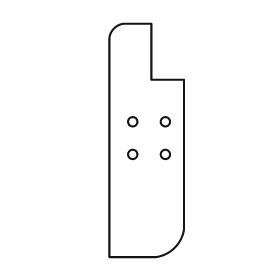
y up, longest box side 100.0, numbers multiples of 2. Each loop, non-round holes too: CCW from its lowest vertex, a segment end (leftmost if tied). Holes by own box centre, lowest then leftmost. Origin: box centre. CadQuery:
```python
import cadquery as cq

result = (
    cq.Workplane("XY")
    .moveTo(-16.0, -50.0)
    .lineTo(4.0, -50.0)
    .threePointArc((12.0, -46.0), (16.0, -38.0))
    .lineTo(16.0, 26.0)
    .lineTo(2.0, 26.0)
    .lineTo(2.0, 50.0)
    .lineTo(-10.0, 50.0)
    .threePointArc((-14.0, 48.0), (-16.0, 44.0))
    .close()
    .moveTo(-6.0, -6.0)
    .circle(2.0)
    .moveTo(8.0, -6.0)
    .circle(2.0)
    .moveTo(-6.0, 8.0)
    .circle(2.0)
    .moveTo(8.0, 8.0)
    .circle(2.0)
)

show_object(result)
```